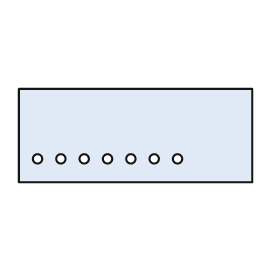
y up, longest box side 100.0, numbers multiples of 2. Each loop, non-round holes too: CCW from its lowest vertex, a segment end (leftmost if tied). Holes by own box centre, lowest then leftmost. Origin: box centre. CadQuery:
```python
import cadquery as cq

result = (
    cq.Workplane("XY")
    .moveTo(-50.0, -20.0)
    .lineTo(50.0, -20.0)
    .lineTo(50.0, 20.0)
    .lineTo(-50.0, 20.0)
    .close()
    .moveTo(-42.0, -10.0)
    .circle(2.0)
    .moveTo(-32.0, -10.0)
    .circle(2.0)
    .moveTo(-22.0, -10.0)
    .circle(2.0)
    .moveTo(-12.0, -10.0)
    .circle(2.0)
    .moveTo(-2.0, -10.0)
    .circle(2.0)
    .moveTo(8.0, -10.0)
    .circle(2.0)
    .moveTo(18.0, -10.0)
    .circle(2.0)
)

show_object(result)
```